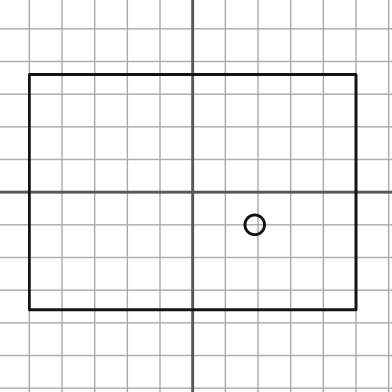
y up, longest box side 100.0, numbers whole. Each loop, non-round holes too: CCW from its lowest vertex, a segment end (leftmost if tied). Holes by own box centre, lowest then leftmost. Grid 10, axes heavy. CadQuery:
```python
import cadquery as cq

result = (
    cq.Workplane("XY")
    .moveTo(-50.0, -36.0)
    .lineTo(50.0, -36.0)
    .lineTo(50.0, 36.0)
    .lineTo(-50.0, 36.0)
    .close()
    .moveTo(19.0, -10.0)
    .circle(3.0)
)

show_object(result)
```